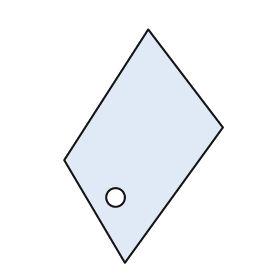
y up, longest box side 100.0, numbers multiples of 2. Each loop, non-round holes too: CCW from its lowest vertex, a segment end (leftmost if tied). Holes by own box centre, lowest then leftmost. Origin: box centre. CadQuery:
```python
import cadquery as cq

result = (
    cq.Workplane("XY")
    .moveTo(-8.0, -50.0)
    .lineTo(34.0, 8.0)
    .lineTo(2.0, 50.0)
    .lineTo(-34.0, -6.0)
    .close()
    .moveTo(-12.0, -22.0)
    .circle(4.0)
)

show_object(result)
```